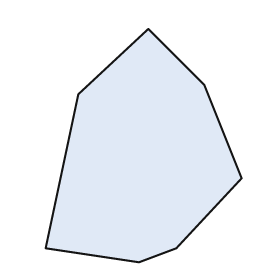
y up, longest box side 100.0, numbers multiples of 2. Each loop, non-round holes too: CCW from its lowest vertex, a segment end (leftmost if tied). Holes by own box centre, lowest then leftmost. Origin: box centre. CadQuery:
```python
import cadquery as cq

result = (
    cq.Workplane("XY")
    .moveTo(-2.0, -50.0)
    .lineTo(14.0, -44.0)
    .lineTo(42.0, -14.0)
    .lineTo(26.0, 26.0)
    .lineTo(2.0, 50.0)
    .lineTo(-28.0, 22.0)
    .lineTo(-42.0, -44.0)
    .close()
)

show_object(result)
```